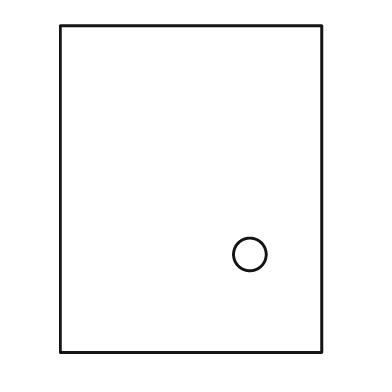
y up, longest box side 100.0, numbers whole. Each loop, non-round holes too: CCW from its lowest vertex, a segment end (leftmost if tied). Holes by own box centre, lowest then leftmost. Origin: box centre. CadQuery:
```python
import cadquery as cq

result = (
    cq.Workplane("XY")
    .moveTo(-40.0, -50.0)
    .lineTo(40.0, -50.0)
    .lineTo(40.0, 50.0)
    .lineTo(-40.0, 50.0)
    .close()
    .moveTo(18.0, -20.0)
    .circle(5.0)
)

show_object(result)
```